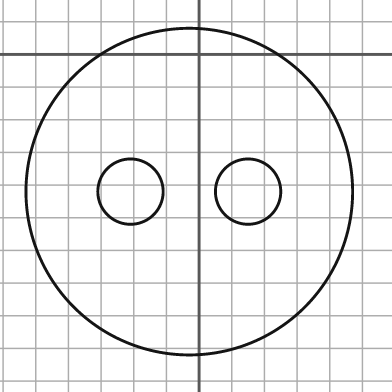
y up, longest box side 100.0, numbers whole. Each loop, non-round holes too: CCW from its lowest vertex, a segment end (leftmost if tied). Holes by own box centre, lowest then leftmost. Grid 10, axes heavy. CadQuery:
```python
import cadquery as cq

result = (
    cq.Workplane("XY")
    .moveTo(-3.0, -42.0)
    .circle(50.0)
    .moveTo(-21.0, -42.0)
    .circle(10.0)
    .moveTo(15.0, -42.0)
    .circle(10.0)
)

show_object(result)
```